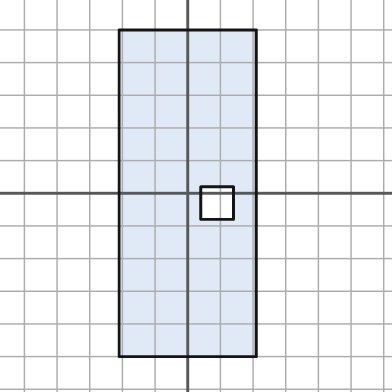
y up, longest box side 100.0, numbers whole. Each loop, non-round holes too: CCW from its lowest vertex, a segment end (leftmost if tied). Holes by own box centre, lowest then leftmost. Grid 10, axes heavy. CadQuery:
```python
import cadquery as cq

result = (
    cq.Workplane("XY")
    .moveTo(-21.0, -50.0)
    .lineTo(21.0, -50.0)
    .lineTo(21.0, 50.0)
    .lineTo(-21.0, 50.0)
    .close()
    .moveTo(4.0, -8.0)
    .lineTo(14.0, -8.0)
    .lineTo(14.0, 2.0)
    .lineTo(4.0, 2.0)
    .close()
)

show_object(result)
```